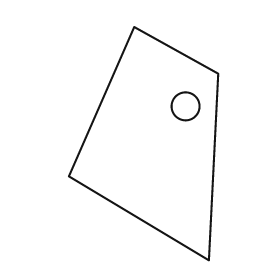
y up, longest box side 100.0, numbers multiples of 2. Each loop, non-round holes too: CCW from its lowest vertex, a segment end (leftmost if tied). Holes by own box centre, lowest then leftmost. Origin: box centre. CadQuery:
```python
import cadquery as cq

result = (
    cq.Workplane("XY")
    .moveTo(28.0, -50.0)
    .lineTo(32.0, 30.0)
    .lineTo(-4.0, 50.0)
    .lineTo(-32.0, -14.0)
    .close()
    .moveTo(18.0, 16.0)
    .circle(6.0)
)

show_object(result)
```